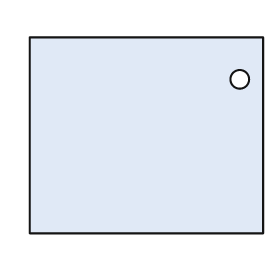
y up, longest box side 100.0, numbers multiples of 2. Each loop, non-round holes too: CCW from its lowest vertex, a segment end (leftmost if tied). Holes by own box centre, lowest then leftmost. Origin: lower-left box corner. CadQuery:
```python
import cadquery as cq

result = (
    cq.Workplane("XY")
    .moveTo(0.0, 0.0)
    .lineTo(100.0, 0.0)
    .lineTo(100.0, 84.0)
    .lineTo(0.0, 84.0)
    .close()
    .moveTo(90.0, 66.0)
    .circle(4.0)
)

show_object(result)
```